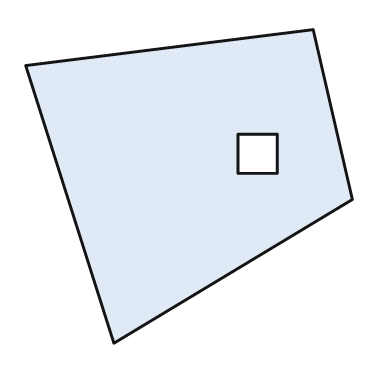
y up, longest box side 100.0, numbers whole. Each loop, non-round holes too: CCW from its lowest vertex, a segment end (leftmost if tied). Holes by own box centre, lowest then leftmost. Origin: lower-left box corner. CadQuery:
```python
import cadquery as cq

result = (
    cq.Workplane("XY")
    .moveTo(27.0, 0.0)
    .lineTo(100.0, 44.0)
    .lineTo(88.0, 96.0)
    .lineTo(0.0, 85.0)
    .close()
    .moveTo(65.0, 52.0)
    .lineTo(77.0, 52.0)
    .lineTo(77.0, 64.0)
    .lineTo(65.0, 64.0)
    .close()
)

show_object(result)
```